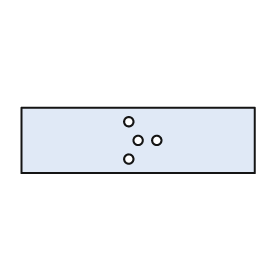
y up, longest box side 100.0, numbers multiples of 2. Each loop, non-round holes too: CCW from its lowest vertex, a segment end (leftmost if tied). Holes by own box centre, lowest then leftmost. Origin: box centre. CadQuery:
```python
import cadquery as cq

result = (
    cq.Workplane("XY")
    .moveTo(-50.0, -14.0)
    .lineTo(50.0, -14.0)
    .lineTo(50.0, 14.0)
    .lineTo(-50.0, 14.0)
    .close()
    .moveTo(-4.0, -8.0)
    .circle(2.0)
    .moveTo(0.0, 0.0)
    .circle(2.0)
    .moveTo(8.0, 0.0)
    .circle(2.0)
    .moveTo(-4.0, 8.0)
    .circle(2.0)
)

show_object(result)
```